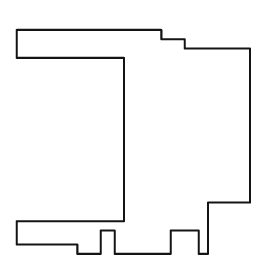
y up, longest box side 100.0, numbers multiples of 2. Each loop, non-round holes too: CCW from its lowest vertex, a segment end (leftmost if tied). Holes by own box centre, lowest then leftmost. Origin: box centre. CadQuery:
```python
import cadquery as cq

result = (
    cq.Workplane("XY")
    .moveTo(-24.0, -48.0)
    .lineTo(-14.0, -48.0)
    .lineTo(-14.0, -38.0)
    .lineTo(-8.0, -38.0)
    .lineTo(-8.0, -48.0)
    .lineTo(16.0, -48.0)
    .lineTo(16.0, -38.0)
    .lineTo(28.0, -38.0)
    .lineTo(28.0, -48.0)
    .lineTo(32.0, -48.0)
    .lineTo(32.0, -26.0)
    .lineTo(50.0, -26.0)
    .lineTo(50.0, 40.0)
    .lineTo(22.0, 40.0)
    .lineTo(22.0, 44.0)
    .lineTo(12.0, 44.0)
    .lineTo(12.0, 48.0)
    .lineTo(-50.0, 48.0)
    .lineTo(-50.0, 36.0)
    .lineTo(-4.0, 36.0)
    .lineTo(-4.0, -34.0)
    .lineTo(-50.0, -34.0)
    .lineTo(-50.0, -44.0)
    .lineTo(-24.0, -44.0)
    .close()
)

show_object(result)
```